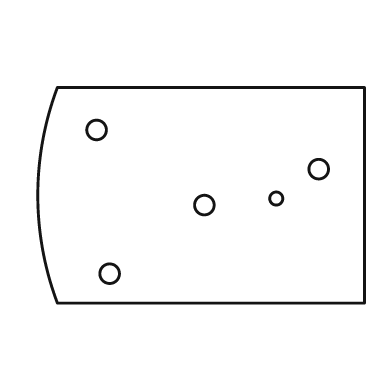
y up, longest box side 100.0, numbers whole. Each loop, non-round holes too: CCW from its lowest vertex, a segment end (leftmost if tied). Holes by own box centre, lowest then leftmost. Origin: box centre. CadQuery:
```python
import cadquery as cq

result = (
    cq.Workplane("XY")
    .moveTo(-44.0, -33.0)
    .lineTo(50.0, -33.0)
    .lineTo(50.0, 33.0)
    .lineTo(-44.0, 33.0)
    .threePointArc((-50.0, 0.0), (-44.0, -33.0))
    .close()
    .moveTo(-28.0, -24.0)
    .circle(3.0)
    .moveTo(1.0, -3.0)
    .circle(3.0)
    .moveTo(23.0, -1.0)
    .circle(2.0)
    .moveTo(36.0, 8.0)
    .circle(3.0)
    .moveTo(-32.0, 20.0)
    .circle(3.0)
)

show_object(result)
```